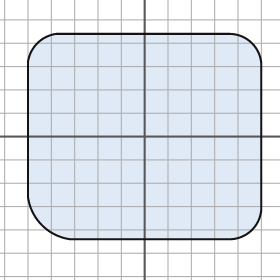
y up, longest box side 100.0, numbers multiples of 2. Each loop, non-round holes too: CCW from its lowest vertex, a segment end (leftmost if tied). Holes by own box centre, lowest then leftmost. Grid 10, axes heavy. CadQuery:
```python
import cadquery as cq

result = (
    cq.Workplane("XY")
    .moveTo(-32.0, -44.0)
    .lineTo(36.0, -44.0)
    .threePointArc((46.0, -40.0), (50.0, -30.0))
    .lineTo(50.0, 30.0)
    .threePointArc((46.0, 40.0), (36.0, 44.0))
    .lineTo(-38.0, 44.0)
    .threePointArc((-46.0, 40.0), (-50.0, 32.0))
    .lineTo(-50.0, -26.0)
    .threePointArc((-44.0, -38.0), (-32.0, -44.0))
    .close()
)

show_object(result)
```